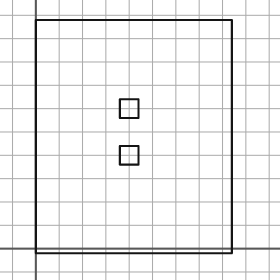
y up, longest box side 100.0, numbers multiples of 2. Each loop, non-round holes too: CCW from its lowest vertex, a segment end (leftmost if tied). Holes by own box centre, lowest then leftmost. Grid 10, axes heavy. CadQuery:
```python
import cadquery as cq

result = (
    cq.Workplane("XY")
    .moveTo(0.0, -2.0)
    .lineTo(84.0, -2.0)
    .lineTo(84.0, 98.0)
    .lineTo(0.0, 98.0)
    .close()
    .moveTo(36.0, 36.0)
    .lineTo(44.0, 36.0)
    .lineTo(44.0, 44.0)
    .lineTo(36.0, 44.0)
    .close()
    .moveTo(36.0, 56.0)
    .lineTo(44.0, 56.0)
    .lineTo(44.0, 64.0)
    .lineTo(36.0, 64.0)
    .close()
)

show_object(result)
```